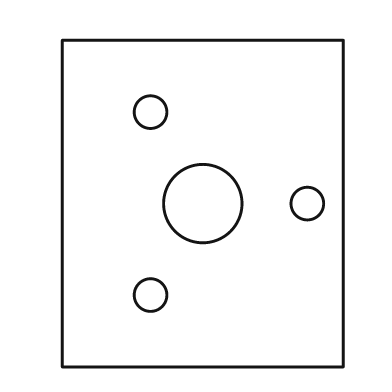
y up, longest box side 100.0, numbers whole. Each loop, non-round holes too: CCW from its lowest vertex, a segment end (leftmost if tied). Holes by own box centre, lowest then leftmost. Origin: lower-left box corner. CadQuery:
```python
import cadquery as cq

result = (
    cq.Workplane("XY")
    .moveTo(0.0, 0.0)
    .lineTo(86.0, 0.0)
    .lineTo(86.0, 100.0)
    .lineTo(0.0, 100.0)
    .close()
    .moveTo(27.0, 22.0)
    .circle(5.0)
    .moveTo(43.0, 50.0)
    .circle(12.0)
    .moveTo(75.0, 50.0)
    .circle(5.0)
    .moveTo(27.0, 78.0)
    .circle(5.0)
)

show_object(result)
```